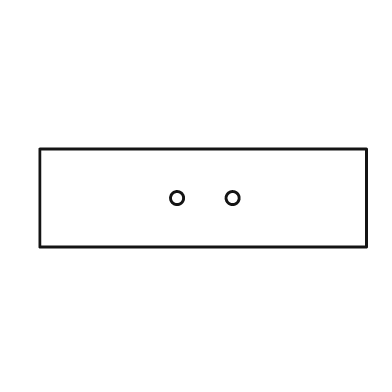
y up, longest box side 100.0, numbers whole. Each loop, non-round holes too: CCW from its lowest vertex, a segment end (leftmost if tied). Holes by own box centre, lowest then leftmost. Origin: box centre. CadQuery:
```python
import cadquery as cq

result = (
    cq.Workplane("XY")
    .moveTo(-50.0, -15.0)
    .lineTo(50.0, -15.0)
    .lineTo(50.0, 15.0)
    .lineTo(-50.0, 15.0)
    .close()
    .moveTo(-8.0, 0.0)
    .circle(2.0)
    .moveTo(9.0, 0.0)
    .circle(2.0)
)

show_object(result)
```